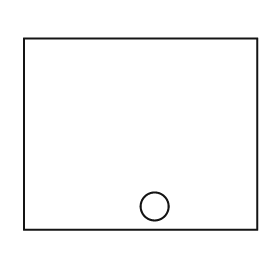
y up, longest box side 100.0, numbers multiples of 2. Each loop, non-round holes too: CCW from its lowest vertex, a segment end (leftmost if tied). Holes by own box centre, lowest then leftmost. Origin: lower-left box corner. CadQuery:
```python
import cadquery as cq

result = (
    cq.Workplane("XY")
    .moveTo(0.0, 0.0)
    .lineTo(100.0, 0.0)
    .lineTo(100.0, 82.0)
    .lineTo(0.0, 82.0)
    .close()
    .moveTo(56.0, 10.0)
    .circle(6.0)
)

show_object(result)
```